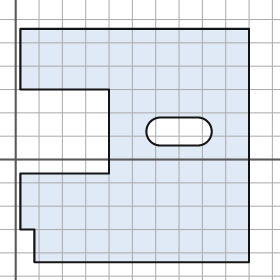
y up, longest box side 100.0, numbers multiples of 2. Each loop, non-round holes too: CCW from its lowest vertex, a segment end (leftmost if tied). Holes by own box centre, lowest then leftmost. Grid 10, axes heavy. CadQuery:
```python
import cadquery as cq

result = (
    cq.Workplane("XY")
    .moveTo(8.0, -44.0)
    .lineTo(100.0, -44.0)
    .lineTo(100.0, 56.0)
    .lineTo(2.0, 56.0)
    .lineTo(2.0, 30.0)
    .lineTo(40.0, 30.0)
    .lineTo(40.0, -6.0)
    .lineTo(2.0, -6.0)
    .lineTo(2.0, -30.0)
    .lineTo(8.0, -30.0)
    .close()
    .moveTo(62.0, 6.0)
    .lineTo(78.0, 6.0)
    .threePointArc((84.0, 12.0), (78.0, 18.0))
    .lineTo(62.0, 18.0)
    .threePointArc((56.0, 12.0), (62.0, 6.0))
    .close()
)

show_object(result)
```